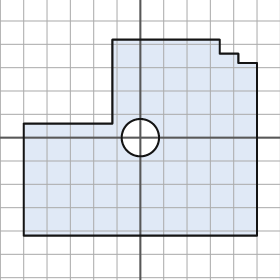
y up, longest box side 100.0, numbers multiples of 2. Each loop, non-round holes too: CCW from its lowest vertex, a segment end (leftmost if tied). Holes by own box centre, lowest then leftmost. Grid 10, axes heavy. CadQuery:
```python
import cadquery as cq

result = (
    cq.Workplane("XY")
    .moveTo(-50.0, -42.0)
    .lineTo(50.0, -42.0)
    .lineTo(50.0, 32.0)
    .lineTo(42.0, 32.0)
    .lineTo(42.0, 36.0)
    .lineTo(34.0, 36.0)
    .lineTo(34.0, 42.0)
    .lineTo(-12.0, 42.0)
    .lineTo(-12.0, 6.0)
    .lineTo(-50.0, 6.0)
    .close()
    .moveTo(0.0, 0.0)
    .circle(8.0)
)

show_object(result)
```